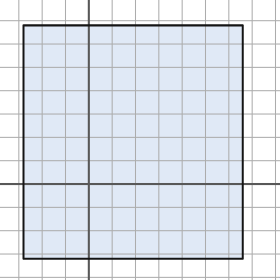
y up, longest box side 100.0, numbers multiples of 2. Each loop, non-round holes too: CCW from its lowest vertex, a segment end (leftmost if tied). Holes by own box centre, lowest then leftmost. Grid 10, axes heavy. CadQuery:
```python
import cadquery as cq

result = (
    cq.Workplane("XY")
    .moveTo(-28.0, -32.0)
    .lineTo(66.0, -32.0)
    .lineTo(66.0, 68.0)
    .lineTo(-28.0, 68.0)
    .close()
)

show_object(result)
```